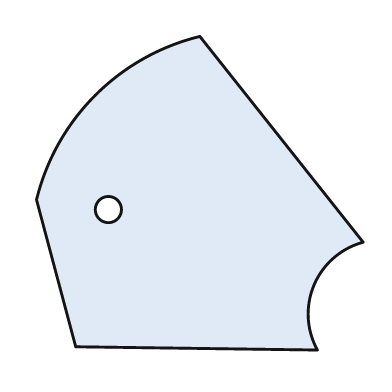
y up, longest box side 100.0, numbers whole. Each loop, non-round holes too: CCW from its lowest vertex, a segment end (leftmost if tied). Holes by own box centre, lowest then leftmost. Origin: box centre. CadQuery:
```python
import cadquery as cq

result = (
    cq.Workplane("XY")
    .moveTo(36.0, -48.0)
    .threePointArc((35.0, -28.0), (50.0, -15.0))
    .lineTo(0.0, 48.0)
    .threePointArc((-32.0, 30.0), (-50.0, -2.0))
    .lineTo(-38.0, -47.0)
    .close()
    .moveTo(-28.0, -5.0)
    .circle(4.0)
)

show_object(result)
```